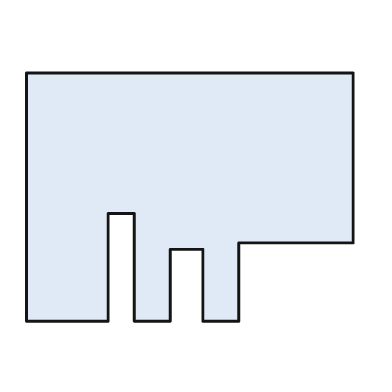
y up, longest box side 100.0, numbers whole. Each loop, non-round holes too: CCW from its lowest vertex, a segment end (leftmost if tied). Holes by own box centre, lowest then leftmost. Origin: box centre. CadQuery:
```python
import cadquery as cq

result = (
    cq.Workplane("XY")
    .moveTo(-50.0, -38.0)
    .lineTo(-25.0, -38.0)
    .lineTo(-25.0, -5.0)
    .lineTo(-17.0, -5.0)
    .lineTo(-17.0, -38.0)
    .lineTo(-6.0, -38.0)
    .lineTo(-6.0, -16.0)
    .lineTo(4.0, -16.0)
    .lineTo(4.0, -38.0)
    .lineTo(15.0, -38.0)
    .lineTo(15.0, -14.0)
    .lineTo(50.0, -14.0)
    .lineTo(50.0, 38.0)
    .lineTo(-50.0, 38.0)
    .close()
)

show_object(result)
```